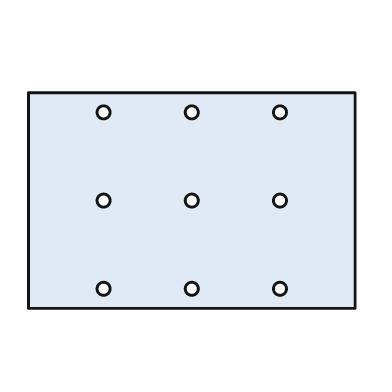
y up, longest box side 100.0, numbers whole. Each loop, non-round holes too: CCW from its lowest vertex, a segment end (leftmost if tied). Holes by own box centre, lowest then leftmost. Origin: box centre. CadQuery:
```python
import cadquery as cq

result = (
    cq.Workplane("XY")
    .moveTo(-50.0, -33.0)
    .lineTo(50.0, -33.0)
    .lineTo(50.0, 33.0)
    .lineTo(-50.0, 33.0)
    .close()
    .moveTo(-27.0, -27.0)
    .circle(2.0)
    .moveTo(0.0, -27.0)
    .circle(2.0)
    .moveTo(27.0, -27.0)
    .circle(2.0)
    .moveTo(-27.0, 0.0)
    .circle(2.0)
    .moveTo(0.0, 0.0)
    .circle(2.0)
    .moveTo(27.0, 0.0)
    .circle(2.0)
    .moveTo(-27.0, 27.0)
    .circle(2.0)
    .moveTo(0.0, 27.0)
    .circle(2.0)
    .moveTo(27.0, 27.0)
    .circle(2.0)
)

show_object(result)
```